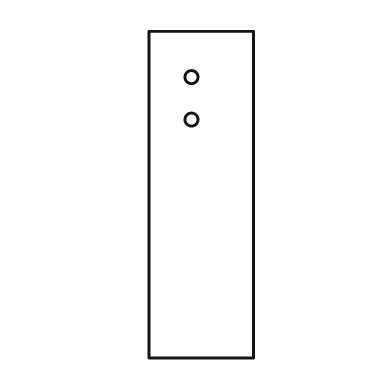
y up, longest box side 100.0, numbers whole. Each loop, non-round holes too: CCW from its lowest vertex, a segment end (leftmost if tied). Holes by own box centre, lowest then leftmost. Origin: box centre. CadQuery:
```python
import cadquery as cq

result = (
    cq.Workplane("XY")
    .moveTo(-16.0, -50.0)
    .lineTo(16.0, -50.0)
    .lineTo(16.0, 50.0)
    .lineTo(-16.0, 50.0)
    .close()
    .moveTo(-3.0, 23.0)
    .circle(2.0)
    .moveTo(-3.0, 36.0)
    .circle(2.0)
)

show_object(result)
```